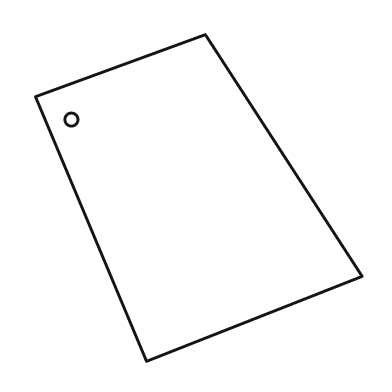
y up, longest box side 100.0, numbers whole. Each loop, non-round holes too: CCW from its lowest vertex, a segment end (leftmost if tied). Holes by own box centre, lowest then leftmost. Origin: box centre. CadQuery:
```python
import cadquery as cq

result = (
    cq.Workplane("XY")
    .moveTo(-16.0, -50.0)
    .lineTo(50.0, -24.0)
    .lineTo(2.0, 50.0)
    .lineTo(-50.0, 31.0)
    .close()
    .moveTo(-39.0, 24.0)
    .circle(2.0)
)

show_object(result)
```